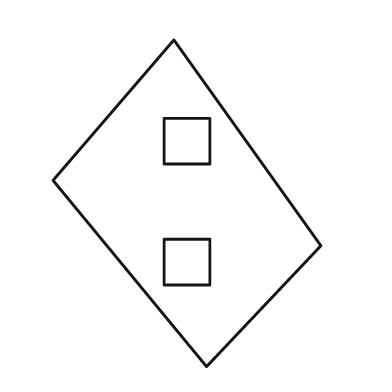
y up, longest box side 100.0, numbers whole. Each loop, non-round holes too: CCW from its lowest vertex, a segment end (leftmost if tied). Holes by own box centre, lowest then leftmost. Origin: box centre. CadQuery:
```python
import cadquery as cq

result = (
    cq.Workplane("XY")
    .moveTo(6.0, -50.0)
    .lineTo(41.0, -13.0)
    .lineTo(-4.0, 50.0)
    .lineTo(-41.0, 7.0)
    .close()
    .moveTo(-7.0, -25.0)
    .lineTo(7.0, -25.0)
    .lineTo(7.0, -11.0)
    .lineTo(-7.0, -11.0)
    .close()
    .moveTo(-7.0, 12.0)
    .lineTo(7.0, 12.0)
    .lineTo(7.0, 26.0)
    .lineTo(-7.0, 26.0)
    .close()
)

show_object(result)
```